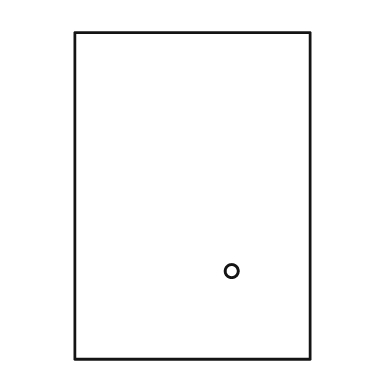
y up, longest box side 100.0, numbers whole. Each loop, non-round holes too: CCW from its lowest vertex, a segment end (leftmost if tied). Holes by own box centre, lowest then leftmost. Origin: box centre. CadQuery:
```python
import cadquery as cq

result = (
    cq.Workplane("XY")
    .moveTo(-36.0, -50.0)
    .lineTo(36.0, -50.0)
    .lineTo(36.0, 50.0)
    .lineTo(-36.0, 50.0)
    .close()
    .moveTo(12.0, -23.0)
    .circle(2.0)
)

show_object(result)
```